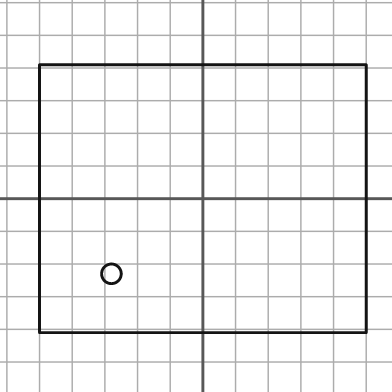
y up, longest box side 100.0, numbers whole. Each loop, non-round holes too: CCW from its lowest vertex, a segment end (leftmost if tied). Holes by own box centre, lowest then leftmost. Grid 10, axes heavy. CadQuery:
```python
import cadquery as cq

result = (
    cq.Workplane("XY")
    .moveTo(-50.0, -41.0)
    .lineTo(50.0, -41.0)
    .lineTo(50.0, 41.0)
    .lineTo(-50.0, 41.0)
    .close()
    .moveTo(-28.0, -23.0)
    .circle(3.0)
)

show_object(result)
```